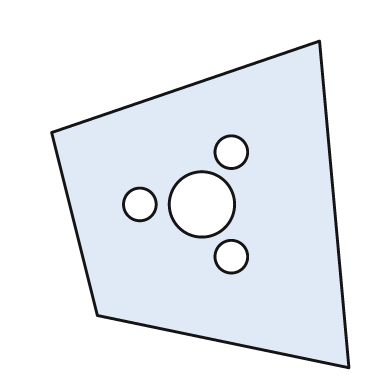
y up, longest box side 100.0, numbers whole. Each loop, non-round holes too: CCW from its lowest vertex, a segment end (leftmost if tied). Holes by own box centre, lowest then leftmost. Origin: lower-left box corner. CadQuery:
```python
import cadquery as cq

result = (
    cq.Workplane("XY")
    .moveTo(91.0, 0.0)
    .lineTo(82.0, 100.0)
    .lineTo(0.0, 72.0)
    .lineTo(14.0, 16.0)
    .close()
    .moveTo(55.0, 34.0)
    .circle(5.0)
    .moveTo(27.0, 50.0)
    .circle(5.0)
    .moveTo(46.0, 50.0)
    .circle(10.0)
    .moveTo(55.0, 66.0)
    .circle(5.0)
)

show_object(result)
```